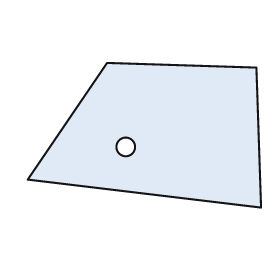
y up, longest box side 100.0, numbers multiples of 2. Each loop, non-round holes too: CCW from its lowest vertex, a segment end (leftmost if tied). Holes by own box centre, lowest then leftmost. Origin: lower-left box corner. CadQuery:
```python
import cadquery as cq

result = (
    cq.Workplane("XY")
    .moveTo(100.0, 0.0)
    .lineTo(98.0, 60.0)
    .lineTo(34.0, 62.0)
    .lineTo(0.0, 12.0)
    .close()
    .moveTo(42.0, 26.0)
    .circle(4.0)
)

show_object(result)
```